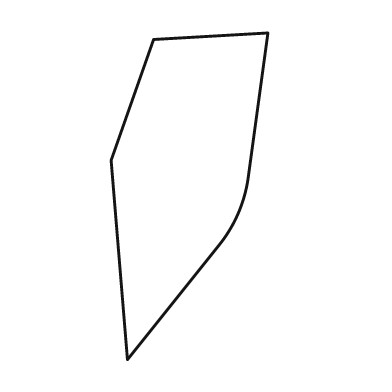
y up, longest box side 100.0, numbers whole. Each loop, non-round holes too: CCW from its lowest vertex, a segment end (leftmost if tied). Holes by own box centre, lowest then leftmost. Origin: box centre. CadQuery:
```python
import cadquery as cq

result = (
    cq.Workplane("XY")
    .moveTo(-19.0, -50.0)
    .lineTo(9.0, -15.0)
    .threePointArc((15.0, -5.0), (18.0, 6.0))
    .lineTo(24.0, 50.0)
    .lineTo(-11.0, 48.0)
    .lineTo(-24.0, 11.0)
    .close()
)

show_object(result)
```